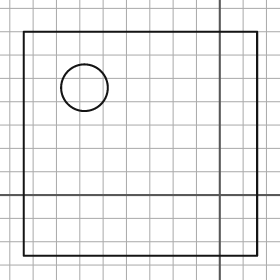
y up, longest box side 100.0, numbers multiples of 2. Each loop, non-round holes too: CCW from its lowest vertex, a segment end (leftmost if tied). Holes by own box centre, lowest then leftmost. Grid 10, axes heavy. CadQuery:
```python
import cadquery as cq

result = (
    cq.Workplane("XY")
    .moveTo(-84.0, -26.0)
    .lineTo(16.0, -26.0)
    .lineTo(16.0, 70.0)
    .lineTo(-84.0, 70.0)
    .close()
    .moveTo(-58.0, 46.0)
    .circle(10.0)
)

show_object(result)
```